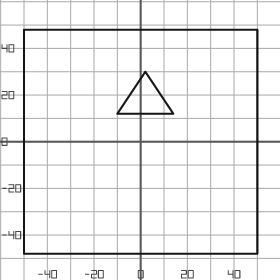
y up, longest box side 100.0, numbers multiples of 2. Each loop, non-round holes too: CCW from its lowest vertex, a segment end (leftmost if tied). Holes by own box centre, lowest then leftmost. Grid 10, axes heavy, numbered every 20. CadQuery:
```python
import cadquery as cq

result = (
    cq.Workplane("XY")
    .moveTo(-50.0, -48.0)
    .lineTo(50.0, -48.0)
    .lineTo(50.0, 48.0)
    .lineTo(-50.0, 48.0)
    .close()
    .moveTo(-10.0, 12.0)
    .lineTo(14.0, 12.0)
    .lineTo(2.0, 30.0)
    .close()
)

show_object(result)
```